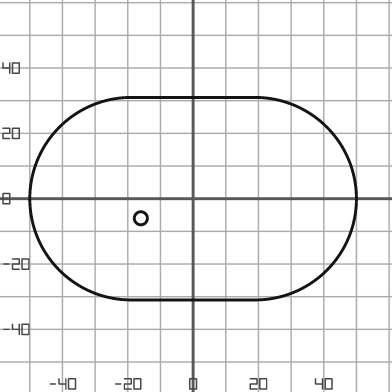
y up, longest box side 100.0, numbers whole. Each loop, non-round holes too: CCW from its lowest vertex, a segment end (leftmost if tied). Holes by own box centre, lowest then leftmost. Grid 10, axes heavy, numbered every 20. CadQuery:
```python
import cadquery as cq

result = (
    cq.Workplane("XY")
    .moveTo(-19.0, -31.0)
    .lineTo(19.0, -31.0)
    .threePointArc((50.0, 0.0), (19.0, 31.0))
    .lineTo(-19.0, 31.0)
    .threePointArc((-50.0, 0.0), (-19.0, -31.0))
    .close()
    .moveTo(-16.0, -6.0)
    .circle(2.0)
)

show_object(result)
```